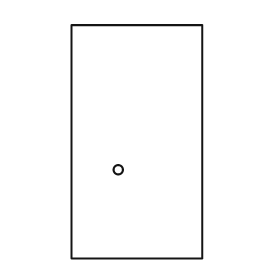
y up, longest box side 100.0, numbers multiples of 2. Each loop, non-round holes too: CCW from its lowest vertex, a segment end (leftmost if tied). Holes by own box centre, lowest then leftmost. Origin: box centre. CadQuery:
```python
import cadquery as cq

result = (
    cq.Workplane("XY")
    .moveTo(-28.0, -50.0)
    .lineTo(28.0, -50.0)
    .lineTo(28.0, 50.0)
    .lineTo(-28.0, 50.0)
    .close()
    .moveTo(-8.0, -12.0)
    .circle(2.0)
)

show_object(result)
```